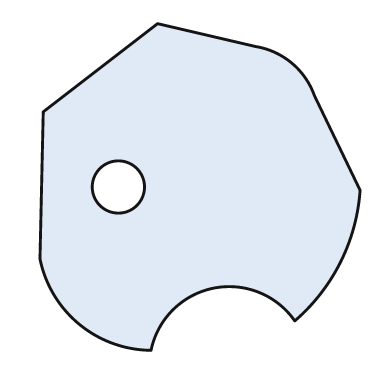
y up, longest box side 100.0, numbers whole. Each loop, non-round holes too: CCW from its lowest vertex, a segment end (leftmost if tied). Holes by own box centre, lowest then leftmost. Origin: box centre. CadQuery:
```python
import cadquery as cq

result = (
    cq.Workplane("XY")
    .moveTo(-15.0, -50.0)
    .threePointArc((4.0, -31.0), (29.0, -41.0))
    .threePointArc((43.0, -23.0), (49.0, -1.0))
    .lineTo(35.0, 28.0)
    .threePointArc((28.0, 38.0), (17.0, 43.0))
    .lineTo(-13.0, 50.0)
    .lineTo(-48.0, 23.0)
    .lineTo(-49.0, -22.0)
    .threePointArc((-37.0, -42.0), (-15.0, -50.0))
    .close()
    .moveTo(-25.0, 0.0)
    .circle(8.0)
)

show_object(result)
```